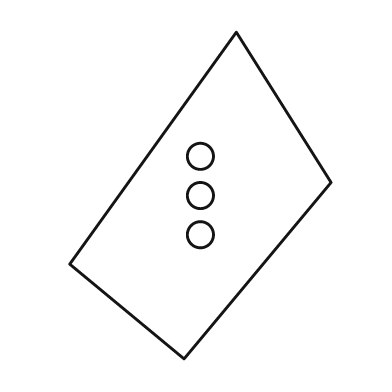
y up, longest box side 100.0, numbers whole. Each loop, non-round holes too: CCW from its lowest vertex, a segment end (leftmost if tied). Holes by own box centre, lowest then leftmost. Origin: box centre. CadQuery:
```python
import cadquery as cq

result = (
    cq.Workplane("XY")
    .moveTo(-5.0, -50.0)
    .lineTo(40.0, 4.0)
    .lineTo(11.0, 50.0)
    .lineTo(-40.0, -21.0)
    .close()
    .moveTo(0.0, -12.0)
    .circle(4.0)
    .moveTo(0.0, 0.0)
    .circle(4.0)
    .moveTo(0.0, 12.0)
    .circle(4.0)
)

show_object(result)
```